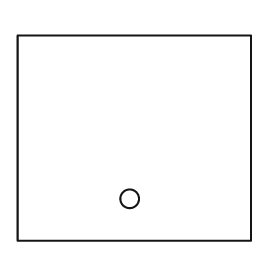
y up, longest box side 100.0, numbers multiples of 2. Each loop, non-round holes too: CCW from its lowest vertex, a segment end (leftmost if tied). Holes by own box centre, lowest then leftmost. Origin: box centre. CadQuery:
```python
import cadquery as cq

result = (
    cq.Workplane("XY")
    .moveTo(-50.0, -44.0)
    .lineTo(50.0, -44.0)
    .lineTo(50.0, 44.0)
    .lineTo(-50.0, 44.0)
    .close()
    .moveTo(-2.0, -26.0)
    .circle(4.0)
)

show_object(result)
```